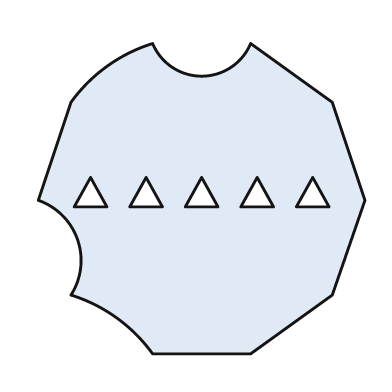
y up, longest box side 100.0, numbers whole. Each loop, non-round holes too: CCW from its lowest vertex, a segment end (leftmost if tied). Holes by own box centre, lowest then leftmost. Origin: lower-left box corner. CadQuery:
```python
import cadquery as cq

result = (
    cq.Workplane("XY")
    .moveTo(35.0, 0.0)
    .lineTo(65.0, 0.0)
    .lineTo(90.0, 18.0)
    .lineTo(100.0, 47.0)
    .lineTo(90.0, 77.0)
    .lineTo(65.0, 95.0)
    .threePointArc((50.0, 85.0), (35.0, 95.0))
    .threePointArc((21.0, 88.0), (10.0, 77.0))
    .lineTo(0.0, 47.0)
    .threePointArc((12.0, 35.0), (10.0, 18.0))
    .threePointArc((24.0, 11.0), (35.0, 0.0))
    .close()
    .moveTo(11.0, 45.0)
    .lineTo(21.0, 45.0)
    .lineTo(16.0, 54.0)
    .close()
    .moveTo(28.0, 45.0)
    .lineTo(38.0, 45.0)
    .lineTo(33.0, 54.0)
    .close()
    .moveTo(45.0, 45.0)
    .lineTo(55.0, 45.0)
    .lineTo(50.0, 54.0)
    .close()
    .moveTo(62.0, 45.0)
    .lineTo(72.0, 45.0)
    .lineTo(67.0, 54.0)
    .close()
    .moveTo(79.0, 45.0)
    .lineTo(89.0, 45.0)
    .lineTo(84.0, 54.0)
    .close()
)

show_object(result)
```